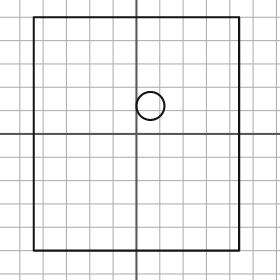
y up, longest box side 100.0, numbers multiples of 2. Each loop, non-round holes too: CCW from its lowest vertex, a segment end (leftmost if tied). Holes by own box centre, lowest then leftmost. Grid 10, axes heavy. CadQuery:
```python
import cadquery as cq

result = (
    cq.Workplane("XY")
    .moveTo(-44.0, -50.0)
    .lineTo(44.0, -50.0)
    .lineTo(44.0, 50.0)
    .lineTo(-44.0, 50.0)
    .close()
    .moveTo(6.0, 12.0)
    .circle(6.0)
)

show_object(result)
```